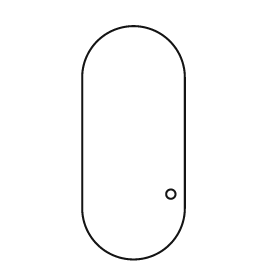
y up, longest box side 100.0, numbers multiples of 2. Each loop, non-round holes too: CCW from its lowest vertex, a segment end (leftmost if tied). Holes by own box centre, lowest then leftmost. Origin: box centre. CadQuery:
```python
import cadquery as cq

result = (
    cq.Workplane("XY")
    .moveTo(-22.0, -28.0)
    .threePointArc((0.0, -50.0), (22.0, -28.0))
    .lineTo(22.0, 28.0)
    .threePointArc((0.0, 50.0), (-22.0, 28.0))
    .close()
    .moveTo(16.0, -22.0)
    .circle(2.0)
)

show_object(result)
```